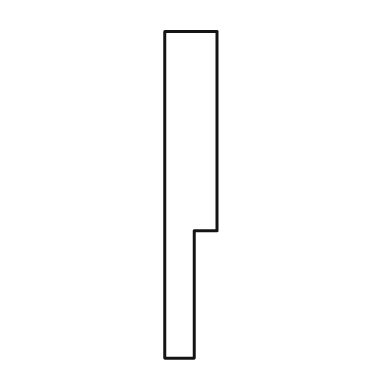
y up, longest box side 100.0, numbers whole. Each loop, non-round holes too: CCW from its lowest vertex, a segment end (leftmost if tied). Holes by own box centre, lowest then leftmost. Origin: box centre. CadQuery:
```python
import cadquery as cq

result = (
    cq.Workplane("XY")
    .moveTo(-8.0, -50.0)
    .lineTo(1.0, -50.0)
    .lineTo(1.0, -11.0)
    .lineTo(8.0, -11.0)
    .lineTo(8.0, 50.0)
    .lineTo(-8.0, 50.0)
    .close()
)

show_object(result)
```